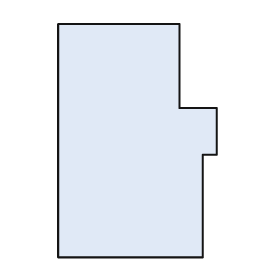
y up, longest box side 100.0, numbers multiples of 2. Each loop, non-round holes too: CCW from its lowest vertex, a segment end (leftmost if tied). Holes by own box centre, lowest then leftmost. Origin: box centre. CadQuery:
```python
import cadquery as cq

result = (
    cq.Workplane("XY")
    .moveTo(-34.0, -50.0)
    .lineTo(28.0, -50.0)
    .lineTo(28.0, -6.0)
    .lineTo(34.0, -6.0)
    .lineTo(34.0, 14.0)
    .lineTo(18.0, 14.0)
    .lineTo(18.0, 50.0)
    .lineTo(-34.0, 50.0)
    .close()
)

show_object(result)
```